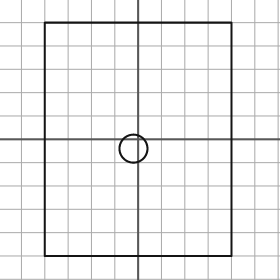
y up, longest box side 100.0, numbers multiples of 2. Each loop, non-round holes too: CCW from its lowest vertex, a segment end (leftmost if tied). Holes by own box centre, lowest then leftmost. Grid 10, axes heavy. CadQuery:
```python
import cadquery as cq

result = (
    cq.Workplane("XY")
    .moveTo(-40.0, -50.0)
    .lineTo(40.0, -50.0)
    .lineTo(40.0, 50.0)
    .lineTo(-40.0, 50.0)
    .close()
    .moveTo(-2.0, -4.0)
    .circle(6.0)
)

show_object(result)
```